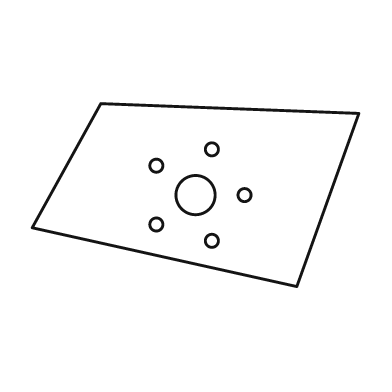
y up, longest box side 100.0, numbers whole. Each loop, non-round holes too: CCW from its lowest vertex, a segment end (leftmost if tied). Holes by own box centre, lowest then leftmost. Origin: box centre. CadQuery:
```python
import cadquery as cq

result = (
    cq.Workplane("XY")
    .moveTo(31.0, -28.0)
    .lineTo(50.0, 25.0)
    .lineTo(-29.0, 28.0)
    .lineTo(-50.0, -10.0)
    .close()
    .moveTo(5.0, -14.0)
    .circle(2.0)
    .moveTo(-12.0, -9.0)
    .circle(2.0)
    .moveTo(0.0, 0.0)
    .circle(6.0)
    .moveTo(15.0, 0.0)
    .circle(2.0)
    .moveTo(-12.0, 9.0)
    .circle(2.0)
    .moveTo(5.0, 14.0)
    .circle(2.0)
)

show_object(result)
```